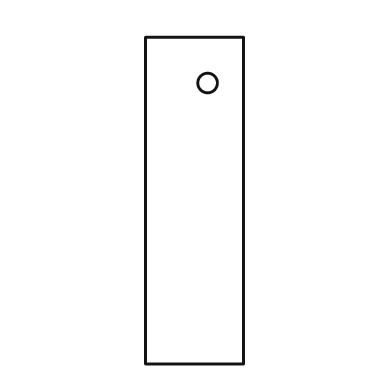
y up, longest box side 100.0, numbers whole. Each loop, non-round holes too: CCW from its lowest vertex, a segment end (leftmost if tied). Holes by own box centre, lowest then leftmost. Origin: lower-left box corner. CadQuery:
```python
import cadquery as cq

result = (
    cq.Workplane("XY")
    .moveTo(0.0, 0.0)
    .lineTo(30.0, 0.0)
    .lineTo(30.0, 100.0)
    .lineTo(0.0, 100.0)
    .close()
    .moveTo(19.0, 86.0)
    .circle(3.0)
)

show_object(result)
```